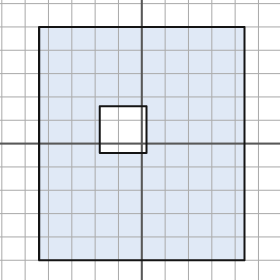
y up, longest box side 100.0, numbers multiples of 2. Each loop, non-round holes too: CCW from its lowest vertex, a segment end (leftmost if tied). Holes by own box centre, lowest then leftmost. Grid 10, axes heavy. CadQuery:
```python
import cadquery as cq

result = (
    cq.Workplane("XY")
    .moveTo(-44.0, -50.0)
    .lineTo(44.0, -50.0)
    .lineTo(44.0, 50.0)
    .lineTo(-44.0, 50.0)
    .close()
    .moveTo(-18.0, -4.0)
    .lineTo(2.0, -4.0)
    .lineTo(2.0, 16.0)
    .lineTo(-18.0, 16.0)
    .close()
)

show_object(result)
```